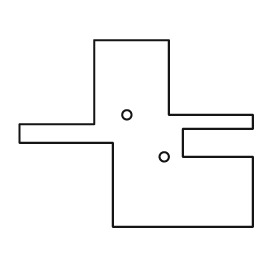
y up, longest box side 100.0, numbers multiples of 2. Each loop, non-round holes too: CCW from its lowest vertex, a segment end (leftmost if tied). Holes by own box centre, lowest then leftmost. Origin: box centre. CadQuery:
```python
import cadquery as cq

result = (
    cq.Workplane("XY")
    .moveTo(-10.0, -40.0)
    .lineTo(50.0, -40.0)
    .lineTo(50.0, -10.0)
    .lineTo(20.0, -10.0)
    .lineTo(20.0, 2.0)
    .lineTo(50.0, 2.0)
    .lineTo(50.0, 8.0)
    .lineTo(14.0, 8.0)
    .lineTo(14.0, 40.0)
    .lineTo(-18.0, 40.0)
    .lineTo(-18.0, 4.0)
    .lineTo(-50.0, 4.0)
    .lineTo(-50.0, -4.0)
    .lineTo(-10.0, -4.0)
    .close()
    .moveTo(12.0, -10.0)
    .circle(2.0)
    .moveTo(-4.0, 8.0)
    .circle(2.0)
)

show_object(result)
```